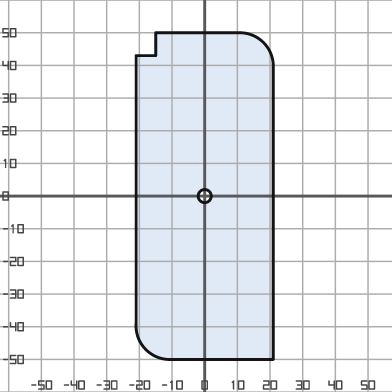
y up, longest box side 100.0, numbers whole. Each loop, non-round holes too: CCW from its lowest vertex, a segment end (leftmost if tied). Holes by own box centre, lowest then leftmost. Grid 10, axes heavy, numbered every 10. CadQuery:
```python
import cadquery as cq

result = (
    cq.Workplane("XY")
    .moveTo(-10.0, -50.0)
    .lineTo(21.0, -50.0)
    .lineTo(21.0, 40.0)
    .threePointArc((18.0, 47.0), (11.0, 50.0))
    .lineTo(-15.0, 50.0)
    .lineTo(-15.0, 43.0)
    .lineTo(-21.0, 43.0)
    .lineTo(-21.0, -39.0)
    .threePointArc((-18.0, -47.0), (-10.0, -50.0))
    .close()
    .moveTo(0.0, 0.0)
    .circle(2.0)
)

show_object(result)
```